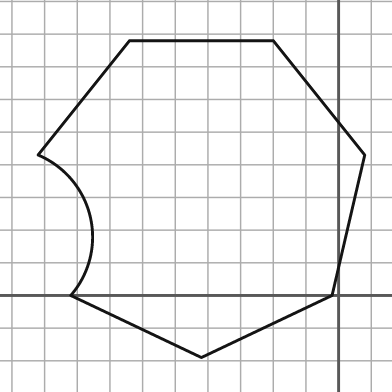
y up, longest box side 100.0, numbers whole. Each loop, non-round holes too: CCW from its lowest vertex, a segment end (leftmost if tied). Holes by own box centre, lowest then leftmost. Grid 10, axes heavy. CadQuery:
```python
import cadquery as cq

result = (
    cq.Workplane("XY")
    .moveTo(-42.0, -19.0)
    .lineTo(-2.0, 0.0)
    .lineTo(8.0, 43.0)
    .lineTo(-20.0, 78.0)
    .lineTo(-64.0, 78.0)
    .lineTo(-92.0, 43.0)
    .threePointArc((-76.0, 24.0), (-82.0, 0.0))
    .close()
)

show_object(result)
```